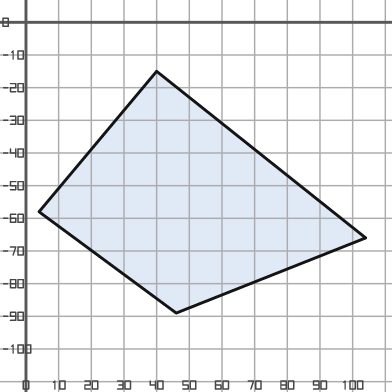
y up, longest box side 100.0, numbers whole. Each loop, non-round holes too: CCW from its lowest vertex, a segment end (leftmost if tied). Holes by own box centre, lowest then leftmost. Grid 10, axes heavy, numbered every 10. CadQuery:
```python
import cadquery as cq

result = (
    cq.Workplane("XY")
    .moveTo(46.0, -89.0)
    .lineTo(104.0, -66.0)
    .lineTo(40.0, -15.0)
    .lineTo(4.0, -58.0)
    .close()
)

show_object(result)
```